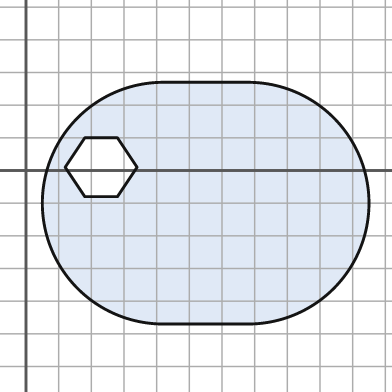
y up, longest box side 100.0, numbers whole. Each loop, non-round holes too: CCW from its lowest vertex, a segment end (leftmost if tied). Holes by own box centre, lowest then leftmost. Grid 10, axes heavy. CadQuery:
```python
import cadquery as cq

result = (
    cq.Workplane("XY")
    .moveTo(42.0, -47.0)
    .lineTo(68.0, -47.0)
    .threePointArc((105.0, -10.0), (68.0, 27.0))
    .lineTo(42.0, 27.0)
    .threePointArc((5.0, -10.0), (42.0, -47.0))
    .close()
    .moveTo(18.0, -8.0)
    .lineTo(28.0, -8.0)
    .lineTo(34.0, 1.0)
    .lineTo(28.0, 10.0)
    .lineTo(18.0, 10.0)
    .lineTo(12.0, 1.0)
    .close()
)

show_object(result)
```